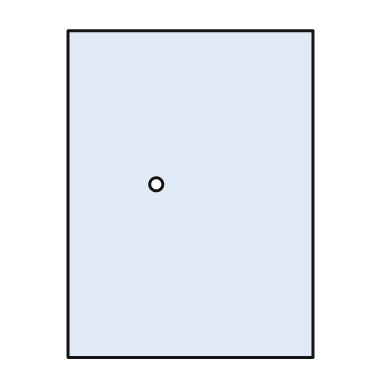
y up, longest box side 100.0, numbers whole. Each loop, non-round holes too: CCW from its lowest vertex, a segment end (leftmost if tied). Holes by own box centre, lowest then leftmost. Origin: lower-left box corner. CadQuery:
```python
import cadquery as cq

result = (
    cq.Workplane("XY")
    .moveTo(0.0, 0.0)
    .lineTo(75.0, 0.0)
    .lineTo(75.0, 100.0)
    .lineTo(0.0, 100.0)
    .close()
    .moveTo(27.0, 53.0)
    .circle(2.0)
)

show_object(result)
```